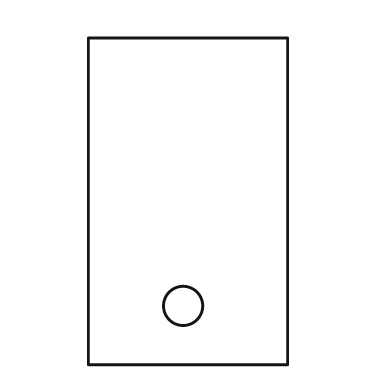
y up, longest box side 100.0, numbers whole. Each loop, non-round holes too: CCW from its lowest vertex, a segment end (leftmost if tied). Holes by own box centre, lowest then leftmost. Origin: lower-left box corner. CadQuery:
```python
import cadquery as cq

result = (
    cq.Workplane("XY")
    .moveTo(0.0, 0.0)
    .lineTo(61.0, 0.0)
    .lineTo(61.0, 100.0)
    .lineTo(0.0, 100.0)
    .close()
    .moveTo(29.0, 18.0)
    .circle(6.0)
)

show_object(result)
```